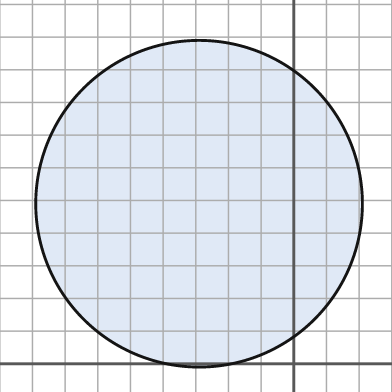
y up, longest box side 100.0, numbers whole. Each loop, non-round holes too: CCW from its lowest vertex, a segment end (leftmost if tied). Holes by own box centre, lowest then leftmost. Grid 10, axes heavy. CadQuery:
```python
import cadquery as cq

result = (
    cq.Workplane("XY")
    .moveTo(-29.0, 49.0)
    .circle(50.0)
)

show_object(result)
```